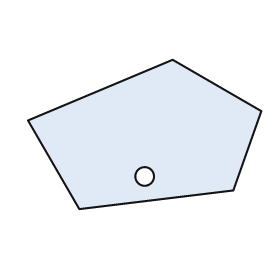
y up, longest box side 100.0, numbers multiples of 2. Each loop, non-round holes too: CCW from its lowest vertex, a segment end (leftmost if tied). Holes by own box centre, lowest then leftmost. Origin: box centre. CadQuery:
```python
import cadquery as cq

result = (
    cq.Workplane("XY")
    .moveTo(-28.0, -32.0)
    .lineTo(38.0, -24.0)
    .lineTo(50.0, 10.0)
    .lineTo(12.0, 32.0)
    .lineTo(-50.0, 6.0)
    .close()
    .moveTo(0.0, -18.0)
    .circle(4.0)
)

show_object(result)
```